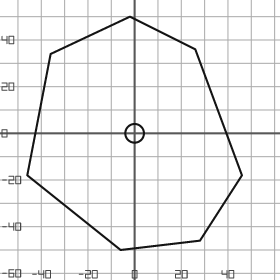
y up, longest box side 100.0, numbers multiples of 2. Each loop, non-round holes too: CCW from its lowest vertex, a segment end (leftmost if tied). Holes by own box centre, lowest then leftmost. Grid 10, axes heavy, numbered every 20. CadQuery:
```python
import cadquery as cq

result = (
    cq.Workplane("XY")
    .moveTo(-6.0, -50.0)
    .lineTo(28.0, -46.0)
    .lineTo(46.0, -18.0)
    .lineTo(26.0, 36.0)
    .lineTo(-2.0, 50.0)
    .lineTo(-36.0, 34.0)
    .lineTo(-46.0, -18.0)
    .close()
    .moveTo(0.0, 0.0)
    .circle(4.0)
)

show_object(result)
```